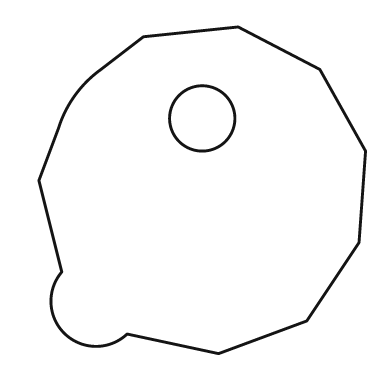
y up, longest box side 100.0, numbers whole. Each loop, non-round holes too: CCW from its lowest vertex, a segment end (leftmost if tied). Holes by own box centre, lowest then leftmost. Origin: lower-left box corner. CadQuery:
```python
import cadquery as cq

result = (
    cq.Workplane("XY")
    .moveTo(55.0, 0.0)
    .lineTo(82.0, 10.0)
    .lineTo(98.0, 34.0)
    .lineTo(100.0, 62.0)
    .lineTo(86.0, 87.0)
    .lineTo(61.0, 100.0)
    .lineTo(32.0, 97.0)
    .lineTo(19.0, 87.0)
    .threePointArc((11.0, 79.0), (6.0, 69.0))
    .lineTo(0.0, 53.0)
    .lineTo(7.0, 25.0)
    .threePointArc((8.0, 6.0), (27.0, 6.0))
    .close()
    .moveTo(50.0, 72.0)
    .circle(10.0)
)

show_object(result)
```